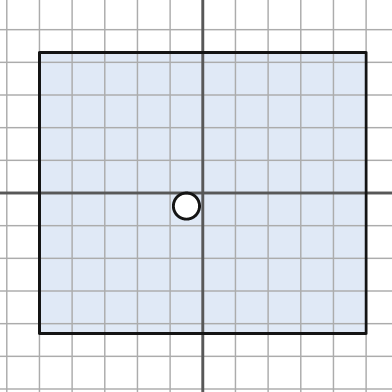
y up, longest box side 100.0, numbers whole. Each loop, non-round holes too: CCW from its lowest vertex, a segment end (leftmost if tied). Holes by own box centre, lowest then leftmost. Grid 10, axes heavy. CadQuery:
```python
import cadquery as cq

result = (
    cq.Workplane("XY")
    .moveTo(-50.0, -43.0)
    .lineTo(50.0, -43.0)
    .lineTo(50.0, 43.0)
    .lineTo(-50.0, 43.0)
    .close()
    .moveTo(-5.0, -4.0)
    .circle(4.0)
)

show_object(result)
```